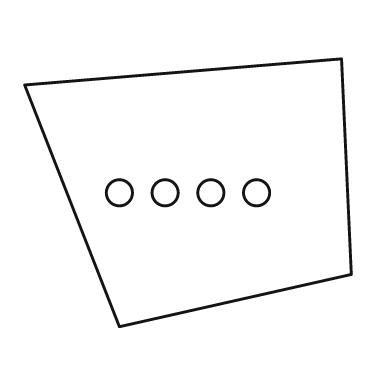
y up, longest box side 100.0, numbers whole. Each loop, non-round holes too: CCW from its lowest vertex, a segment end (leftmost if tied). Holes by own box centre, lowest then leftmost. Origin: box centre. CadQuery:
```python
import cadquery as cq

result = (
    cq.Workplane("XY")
    .moveTo(-21.0, -41.0)
    .lineTo(50.0, -25.0)
    .lineTo(47.0, 41.0)
    .lineTo(-50.0, 33.0)
    .close()
    .moveTo(-21.0, 0.0)
    .circle(4.0)
    .moveTo(-7.0, 0.0)
    .circle(4.0)
    .moveTo(7.0, 0.0)
    .circle(4.0)
    .moveTo(21.0, 0.0)
    .circle(4.0)
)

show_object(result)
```